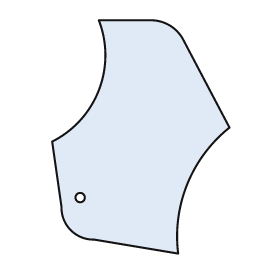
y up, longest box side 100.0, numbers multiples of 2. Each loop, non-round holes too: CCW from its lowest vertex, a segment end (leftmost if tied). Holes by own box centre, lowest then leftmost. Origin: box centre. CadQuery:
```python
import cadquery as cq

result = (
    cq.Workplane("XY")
    .moveTo(16.0, -50.0)
    .threePointArc((20.0, -20.0), (38.0, 4.0))
    .lineTo(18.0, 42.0)
    .threePointArc((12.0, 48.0), (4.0, 50.0))
    .lineTo(-18.0, 50.0)
    .threePointArc((-18.0, 20.0), (-38.0, -2.0))
    .lineTo(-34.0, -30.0)
    .threePointArc((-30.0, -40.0), (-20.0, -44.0))
    .close()
    .moveTo(-26.0, -26.0)
    .circle(2.0)
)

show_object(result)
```